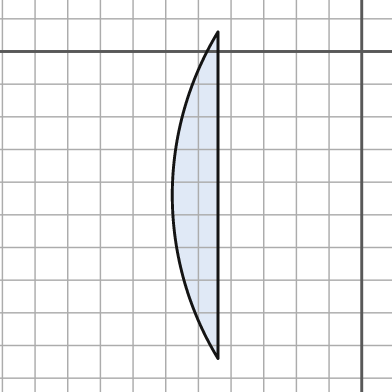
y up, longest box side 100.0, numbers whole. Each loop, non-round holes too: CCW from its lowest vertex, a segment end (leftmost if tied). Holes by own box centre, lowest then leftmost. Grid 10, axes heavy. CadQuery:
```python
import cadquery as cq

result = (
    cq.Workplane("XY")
    .moveTo(-44.0, -94.0)
    .lineTo(-44.0, 6.0)
    .threePointArc((-58.0, -44.0), (-44.0, -94.0))
    .close()
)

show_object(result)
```